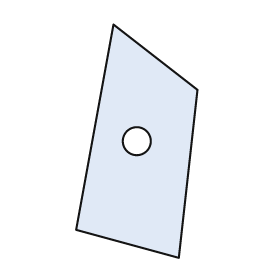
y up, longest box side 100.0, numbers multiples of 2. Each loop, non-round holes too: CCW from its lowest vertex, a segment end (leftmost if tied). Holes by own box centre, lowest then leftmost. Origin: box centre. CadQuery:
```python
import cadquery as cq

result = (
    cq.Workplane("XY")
    .moveTo(18.0, -50.0)
    .lineTo(26.0, 22.0)
    .lineTo(-10.0, 50.0)
    .lineTo(-26.0, -38.0)
    .close()
    .moveTo(0.0, 0.0)
    .circle(6.0)
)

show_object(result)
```